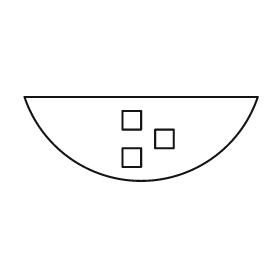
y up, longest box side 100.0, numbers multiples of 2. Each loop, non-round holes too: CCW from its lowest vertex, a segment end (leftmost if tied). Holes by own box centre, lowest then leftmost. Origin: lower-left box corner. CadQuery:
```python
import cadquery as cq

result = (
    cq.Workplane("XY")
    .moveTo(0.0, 36.0)
    .threePointArc((50.0, 0.0), (100.0, 36.0))
    .close()
    .moveTo(42.0, 6.0)
    .lineTo(50.0, 6.0)
    .lineTo(50.0, 14.0)
    .lineTo(42.0, 14.0)
    .close()
    .moveTo(56.0, 14.0)
    .lineTo(64.0, 14.0)
    .lineTo(64.0, 22.0)
    .lineTo(56.0, 22.0)
    .close()
    .moveTo(42.0, 22.0)
    .lineTo(50.0, 22.0)
    .lineTo(50.0, 30.0)
    .lineTo(42.0, 30.0)
    .close()
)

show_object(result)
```